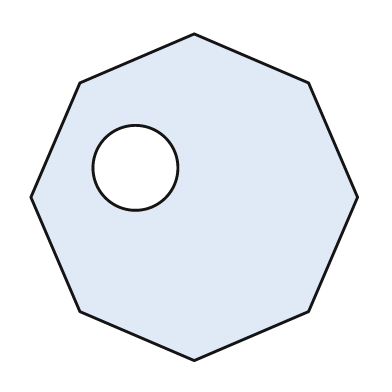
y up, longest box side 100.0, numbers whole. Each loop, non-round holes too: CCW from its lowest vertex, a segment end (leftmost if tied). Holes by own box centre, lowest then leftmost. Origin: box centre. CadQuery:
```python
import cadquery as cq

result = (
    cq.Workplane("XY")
    .moveTo(0.0, -50.0)
    .lineTo(35.0, -35.0)
    .lineTo(50.0, 0.0)
    .lineTo(35.0, 35.0)
    .lineTo(0.0, 50.0)
    .lineTo(-35.0, 35.0)
    .lineTo(-50.0, 0.0)
    .lineTo(-35.0, -35.0)
    .close()
    .moveTo(-18.0, 9.0)
    .circle(13.0)
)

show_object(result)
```